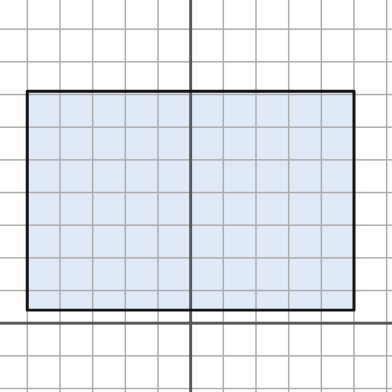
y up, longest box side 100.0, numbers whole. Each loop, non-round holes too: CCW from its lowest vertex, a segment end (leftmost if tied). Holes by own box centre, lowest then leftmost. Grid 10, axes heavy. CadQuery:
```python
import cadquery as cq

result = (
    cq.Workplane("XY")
    .moveTo(-50.0, 4.0)
    .lineTo(50.0, 4.0)
    .lineTo(50.0, 71.0)
    .lineTo(-50.0, 71.0)
    .close()
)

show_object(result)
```